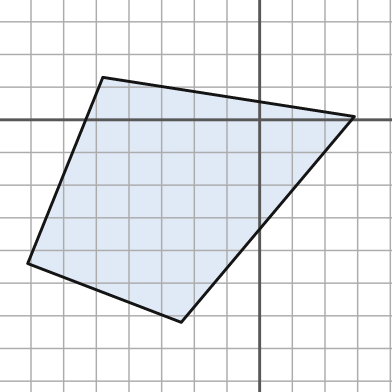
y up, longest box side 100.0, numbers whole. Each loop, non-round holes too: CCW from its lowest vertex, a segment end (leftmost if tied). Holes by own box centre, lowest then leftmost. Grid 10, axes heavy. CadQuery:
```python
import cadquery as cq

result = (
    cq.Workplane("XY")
    .moveTo(-24.0, -62.0)
    .lineTo(29.0, 1.0)
    .lineTo(-48.0, 13.0)
    .lineTo(-71.0, -44.0)
    .close()
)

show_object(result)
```